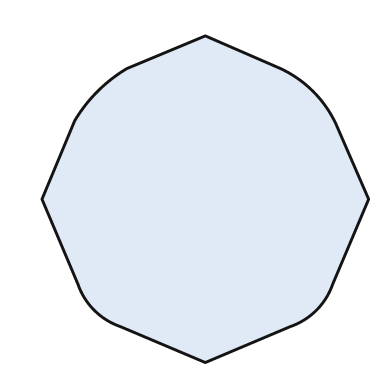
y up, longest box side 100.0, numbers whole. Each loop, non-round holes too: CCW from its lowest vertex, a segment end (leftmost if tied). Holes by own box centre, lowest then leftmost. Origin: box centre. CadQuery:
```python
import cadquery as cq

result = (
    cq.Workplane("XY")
    .moveTo(0.0, -50.0)
    .lineTo(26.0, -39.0)
    .threePointArc((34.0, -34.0), (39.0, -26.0))
    .lineTo(50.0, 0.0)
    .lineTo(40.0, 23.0)
    .threePointArc((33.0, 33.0), (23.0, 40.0))
    .lineTo(0.0, 50.0)
    .lineTo(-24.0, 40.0)
    .threePointArc((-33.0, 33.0), (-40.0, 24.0))
    .lineTo(-50.0, 0.0)
    .lineTo(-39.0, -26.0)
    .threePointArc((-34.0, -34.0), (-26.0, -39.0))
    .close()
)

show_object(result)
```